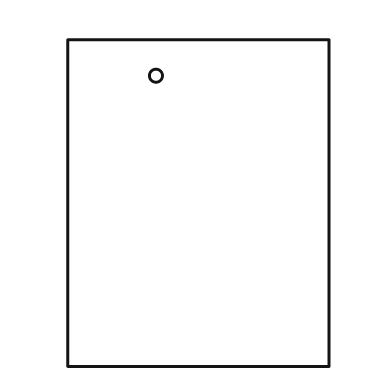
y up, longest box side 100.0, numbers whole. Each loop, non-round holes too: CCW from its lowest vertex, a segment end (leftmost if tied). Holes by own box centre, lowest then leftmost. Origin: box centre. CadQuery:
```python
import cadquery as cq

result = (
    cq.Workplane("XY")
    .moveTo(-40.0, -50.0)
    .lineTo(40.0, -50.0)
    .lineTo(40.0, 50.0)
    .lineTo(-40.0, 50.0)
    .close()
    .moveTo(-13.0, 39.0)
    .circle(2.0)
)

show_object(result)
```